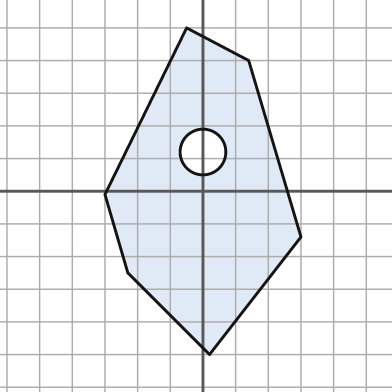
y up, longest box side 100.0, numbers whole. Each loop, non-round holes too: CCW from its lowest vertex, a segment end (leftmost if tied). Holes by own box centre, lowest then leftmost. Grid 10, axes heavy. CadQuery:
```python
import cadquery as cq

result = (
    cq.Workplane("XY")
    .moveTo(2.0, -50.0)
    .lineTo(30.0, -14.0)
    .lineTo(14.0, 40.0)
    .lineTo(-5.0, 50.0)
    .lineTo(-30.0, -1.0)
    .lineTo(-23.0, -25.0)
    .close()
    .moveTo(0.0, 12.0)
    .circle(7.0)
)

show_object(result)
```